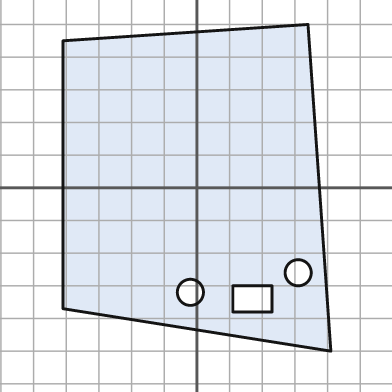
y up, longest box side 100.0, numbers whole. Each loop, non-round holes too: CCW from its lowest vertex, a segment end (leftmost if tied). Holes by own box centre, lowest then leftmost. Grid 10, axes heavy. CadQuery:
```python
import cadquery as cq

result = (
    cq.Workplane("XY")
    .moveTo(41.0, -50.0)
    .lineTo(34.0, 50.0)
    .lineTo(-41.0, 45.0)
    .lineTo(-41.0, -37.0)
    .close()
    .moveTo(11.0, -38.0)
    .lineTo(23.0, -38.0)
    .lineTo(23.0, -30.0)
    .lineTo(11.0, -30.0)
    .close()
    .moveTo(-2.0, -32.0)
    .circle(4.0)
    .moveTo(31.0, -26.0)
    .circle(4.0)
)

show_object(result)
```